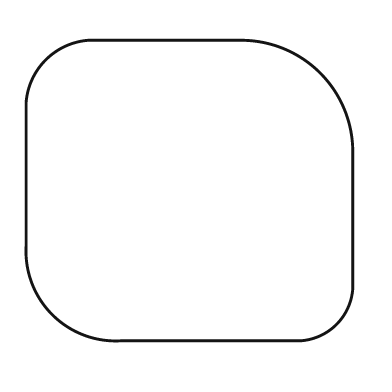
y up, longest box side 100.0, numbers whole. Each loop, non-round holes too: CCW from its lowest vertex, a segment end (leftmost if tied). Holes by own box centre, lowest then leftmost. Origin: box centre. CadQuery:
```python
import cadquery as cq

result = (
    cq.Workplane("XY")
    .moveTo(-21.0, -46.0)
    .lineTo(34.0, -46.0)
    .threePointArc((45.0, -41.0), (50.0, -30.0))
    .lineTo(50.0, 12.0)
    .threePointArc((40.0, 36.0), (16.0, 46.0))
    .lineTo(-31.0, 46.0)
    .threePointArc((-44.0, 40.0), (-50.0, 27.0))
    .lineTo(-50.0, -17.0)
    .threePointArc((-42.0, -38.0), (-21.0, -46.0))
    .close()
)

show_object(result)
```